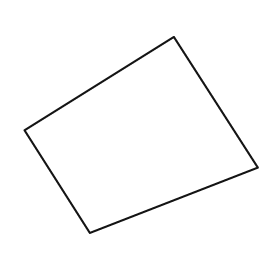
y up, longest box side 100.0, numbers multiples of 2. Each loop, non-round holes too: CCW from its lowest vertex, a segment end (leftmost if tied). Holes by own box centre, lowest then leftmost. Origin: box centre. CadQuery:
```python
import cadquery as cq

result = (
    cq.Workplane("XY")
    .moveTo(-22.0, -42.0)
    .lineTo(50.0, -14.0)
    .lineTo(14.0, 42.0)
    .lineTo(-50.0, 2.0)
    .close()
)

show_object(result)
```